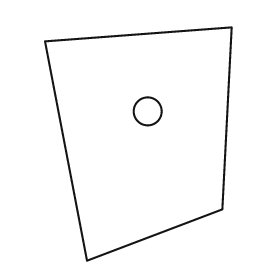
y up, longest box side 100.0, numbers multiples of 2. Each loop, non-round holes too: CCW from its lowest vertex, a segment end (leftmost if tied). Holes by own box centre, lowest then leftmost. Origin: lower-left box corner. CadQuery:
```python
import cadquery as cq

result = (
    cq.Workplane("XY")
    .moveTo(18.0, 0.0)
    .lineTo(76.0, 22.0)
    .lineTo(80.0, 100.0)
    .lineTo(0.0, 94.0)
    .close()
    .moveTo(44.0, 64.0)
    .circle(6.0)
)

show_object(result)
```